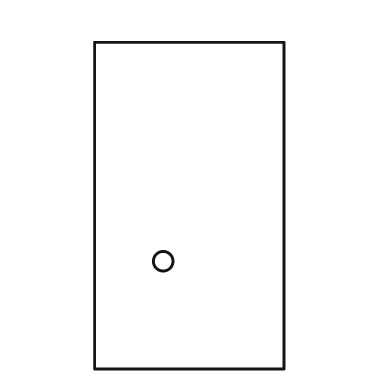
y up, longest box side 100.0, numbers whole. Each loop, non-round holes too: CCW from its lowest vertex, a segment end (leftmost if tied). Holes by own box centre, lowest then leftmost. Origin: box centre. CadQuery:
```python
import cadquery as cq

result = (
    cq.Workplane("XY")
    .moveTo(-29.0, -50.0)
    .lineTo(29.0, -50.0)
    .lineTo(29.0, 50.0)
    .lineTo(-29.0, 50.0)
    .close()
    .moveTo(-8.0, -17.0)
    .circle(3.0)
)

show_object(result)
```